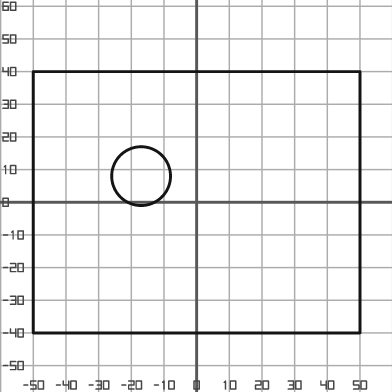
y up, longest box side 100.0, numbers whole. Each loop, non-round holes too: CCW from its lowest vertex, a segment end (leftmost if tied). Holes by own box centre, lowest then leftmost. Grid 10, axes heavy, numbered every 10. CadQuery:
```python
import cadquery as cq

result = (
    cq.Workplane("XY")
    .moveTo(-50.0, -40.0)
    .lineTo(50.0, -40.0)
    .lineTo(50.0, 40.0)
    .lineTo(-50.0, 40.0)
    .close()
    .moveTo(-17.0, 8.0)
    .circle(9.0)
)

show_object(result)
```